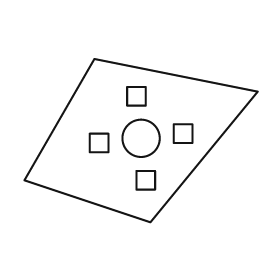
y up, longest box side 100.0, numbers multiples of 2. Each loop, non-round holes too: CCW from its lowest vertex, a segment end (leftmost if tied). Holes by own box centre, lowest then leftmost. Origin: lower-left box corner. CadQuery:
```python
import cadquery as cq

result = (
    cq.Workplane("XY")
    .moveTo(54.0, 0.0)
    .lineTo(100.0, 56.0)
    .lineTo(30.0, 70.0)
    .lineTo(0.0, 18.0)
    .close()
    .moveTo(48.0, 14.0)
    .lineTo(56.0, 14.0)
    .lineTo(56.0, 22.0)
    .lineTo(48.0, 22.0)
    .close()
    .moveTo(28.0, 30.0)
    .lineTo(36.0, 30.0)
    .lineTo(36.0, 38.0)
    .lineTo(28.0, 38.0)
    .close()
    .moveTo(50.0, 36.0)
    .circle(8.0)
    .moveTo(64.0, 34.0)
    .lineTo(72.0, 34.0)
    .lineTo(72.0, 42.0)
    .lineTo(64.0, 42.0)
    .close()
    .moveTo(44.0, 50.0)
    .lineTo(52.0, 50.0)
    .lineTo(52.0, 58.0)
    .lineTo(44.0, 58.0)
    .close()
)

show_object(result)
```